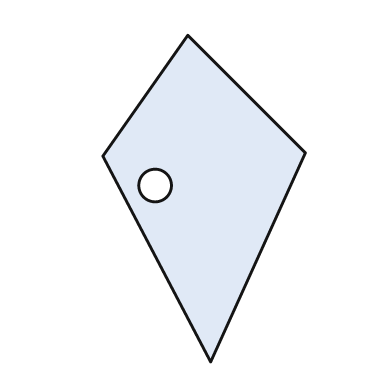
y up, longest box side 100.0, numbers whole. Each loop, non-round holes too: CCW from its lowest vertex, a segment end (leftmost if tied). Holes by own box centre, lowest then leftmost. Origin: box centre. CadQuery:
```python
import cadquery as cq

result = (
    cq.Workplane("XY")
    .moveTo(2.0, -50.0)
    .lineTo(31.0, 14.0)
    .lineTo(-5.0, 50.0)
    .lineTo(-31.0, 13.0)
    .close()
    .moveTo(-15.0, 4.0)
    .circle(5.0)
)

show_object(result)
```